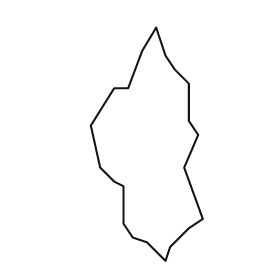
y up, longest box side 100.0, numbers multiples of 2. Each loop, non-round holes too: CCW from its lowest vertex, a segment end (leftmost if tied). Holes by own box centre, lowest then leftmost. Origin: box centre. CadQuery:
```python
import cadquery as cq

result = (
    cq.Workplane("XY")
    .moveTo(8.0, -50.0)
    .lineTo(10.0, -44.0)
    .lineTo(18.0, -36.0)
    .lineTo(24.0, -32.0)
    .lineTo(16.0, -10.0)
    .lineTo(22.0, 4.0)
    .lineTo(18.0, 10.0)
    .lineTo(18.0, 26.0)
    .lineTo(12.0, 32.0)
    .lineTo(8.0, 38.0)
    .lineTo(4.0, 50.0)
    .lineTo(-2.0, 40.0)
    .lineTo(-8.0, 24.0)
    .lineTo(-14.0, 24.0)
    .lineTo(-24.0, 8.0)
    .lineTo(-20.0, -10.0)
    .lineTo(-14.0, -16.0)
    .lineTo(-10.0, -18.0)
    .lineTo(-10.0, -34.0)
    .lineTo(-6.0, -40.0)
    .lineTo(0.0, -42.0)
    .close()
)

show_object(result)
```